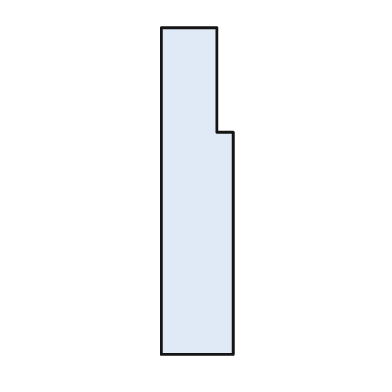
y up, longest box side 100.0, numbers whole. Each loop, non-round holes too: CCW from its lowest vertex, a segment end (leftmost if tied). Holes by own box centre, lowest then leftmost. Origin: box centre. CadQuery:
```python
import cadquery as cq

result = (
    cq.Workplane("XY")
    .moveTo(-11.0, -50.0)
    .lineTo(11.0, -50.0)
    .lineTo(11.0, 18.0)
    .lineTo(6.0, 18.0)
    .lineTo(6.0, 50.0)
    .lineTo(-11.0, 50.0)
    .close()
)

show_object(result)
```